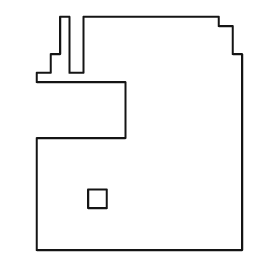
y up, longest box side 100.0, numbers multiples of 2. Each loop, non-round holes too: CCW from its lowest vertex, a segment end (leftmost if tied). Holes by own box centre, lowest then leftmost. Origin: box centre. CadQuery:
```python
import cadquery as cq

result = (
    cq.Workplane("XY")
    .moveTo(-44.0, -50.0)
    .lineTo(44.0, -50.0)
    .lineTo(44.0, 34.0)
    .lineTo(40.0, 34.0)
    .lineTo(40.0, 46.0)
    .lineTo(34.0, 46.0)
    .lineTo(34.0, 50.0)
    .lineTo(-24.0, 50.0)
    .lineTo(-24.0, 26.0)
    .lineTo(-30.0, 26.0)
    .lineTo(-30.0, 50.0)
    .lineTo(-34.0, 50.0)
    .lineTo(-34.0, 34.0)
    .lineTo(-38.0, 34.0)
    .lineTo(-38.0, 26.0)
    .lineTo(-44.0, 26.0)
    .lineTo(-44.0, 22.0)
    .lineTo(-6.0, 22.0)
    .lineTo(-6.0, -2.0)
    .lineTo(-44.0, -2.0)
    .close()
    .moveTo(-22.0, -32.0)
    .lineTo(-14.0, -32.0)
    .lineTo(-14.0, -24.0)
    .lineTo(-22.0, -24.0)
    .close()
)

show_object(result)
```